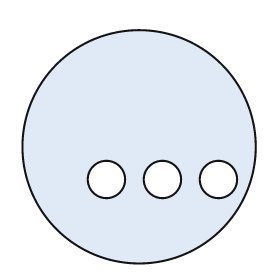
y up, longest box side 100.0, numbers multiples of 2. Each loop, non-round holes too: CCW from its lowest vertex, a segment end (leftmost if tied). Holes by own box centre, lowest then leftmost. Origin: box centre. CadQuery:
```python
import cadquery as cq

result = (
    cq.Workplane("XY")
    .moveTo(0.0, 0.0)
    .circle(50.0)
    .moveTo(-14.0, -14.0)
    .circle(8.0)
    .moveTo(10.0, -14.0)
    .circle(8.0)
    .moveTo(34.0, -14.0)
    .circle(8.0)
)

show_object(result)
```